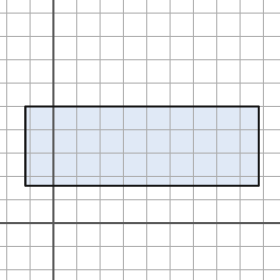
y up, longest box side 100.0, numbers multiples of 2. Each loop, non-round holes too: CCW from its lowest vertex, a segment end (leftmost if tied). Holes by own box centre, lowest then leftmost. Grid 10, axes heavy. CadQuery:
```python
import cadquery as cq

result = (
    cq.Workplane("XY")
    .moveTo(-12.0, 16.0)
    .lineTo(88.0, 16.0)
    .lineTo(88.0, 50.0)
    .lineTo(-12.0, 50.0)
    .close()
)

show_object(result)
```